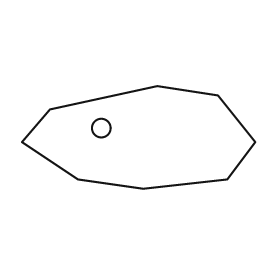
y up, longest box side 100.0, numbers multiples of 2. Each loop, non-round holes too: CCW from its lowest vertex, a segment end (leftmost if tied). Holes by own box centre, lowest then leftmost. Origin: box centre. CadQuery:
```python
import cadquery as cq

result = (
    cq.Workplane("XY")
    .moveTo(2.0, -22.0)
    .lineTo(38.0, -18.0)
    .lineTo(50.0, -2.0)
    .lineTo(34.0, 18.0)
    .lineTo(8.0, 22.0)
    .lineTo(-38.0, 12.0)
    .lineTo(-50.0, -2.0)
    .lineTo(-26.0, -18.0)
    .close()
    .moveTo(-16.0, 4.0)
    .circle(4.0)
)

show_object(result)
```